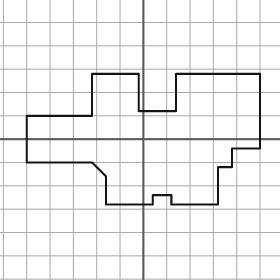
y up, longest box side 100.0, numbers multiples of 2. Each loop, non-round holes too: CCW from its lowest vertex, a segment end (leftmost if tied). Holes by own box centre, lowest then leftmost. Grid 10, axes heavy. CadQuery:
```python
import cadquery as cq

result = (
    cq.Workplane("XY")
    .moveTo(-16.0, -28.0)
    .lineTo(4.0, -28.0)
    .lineTo(4.0, -24.0)
    .lineTo(12.0, -24.0)
    .lineTo(12.0, -28.0)
    .lineTo(32.0, -28.0)
    .lineTo(32.0, -12.0)
    .lineTo(38.0, -12.0)
    .lineTo(38.0, -4.0)
    .lineTo(50.0, -4.0)
    .lineTo(50.0, 28.0)
    .lineTo(14.0, 28.0)
    .lineTo(14.0, 12.0)
    .lineTo(-2.0, 12.0)
    .lineTo(-2.0, 28.0)
    .lineTo(-22.0, 28.0)
    .lineTo(-22.0, 10.0)
    .lineTo(-50.0, 10.0)
    .lineTo(-50.0, -10.0)
    .lineTo(-22.0, -10.0)
    .lineTo(-16.0, -16.0)
    .close()
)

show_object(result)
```